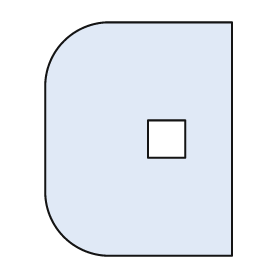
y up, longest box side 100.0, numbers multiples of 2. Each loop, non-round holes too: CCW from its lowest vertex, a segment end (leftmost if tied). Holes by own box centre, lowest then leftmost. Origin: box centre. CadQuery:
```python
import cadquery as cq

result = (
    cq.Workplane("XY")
    .moveTo(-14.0, -50.0)
    .lineTo(40.0, -50.0)
    .lineTo(40.0, 50.0)
    .lineTo(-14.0, 50.0)
    .threePointArc((-32.0, 42.0), (-40.0, 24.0))
    .lineTo(-40.0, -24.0)
    .threePointArc((-32.0, -42.0), (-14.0, -50.0))
    .close()
    .moveTo(4.0, -8.0)
    .lineTo(20.0, -8.0)
    .lineTo(20.0, 8.0)
    .lineTo(4.0, 8.0)
    .close()
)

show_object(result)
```